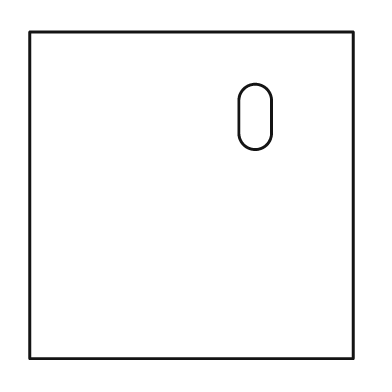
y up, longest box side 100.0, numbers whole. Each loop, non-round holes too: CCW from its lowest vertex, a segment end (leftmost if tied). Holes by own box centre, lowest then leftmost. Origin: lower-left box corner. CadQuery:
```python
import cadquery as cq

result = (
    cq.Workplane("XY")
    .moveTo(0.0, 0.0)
    .lineTo(99.0, 0.0)
    .lineTo(99.0, 100.0)
    .lineTo(0.0, 100.0)
    .close()
    .moveTo(64.0, 69.0)
    .threePointArc((69.0, 64.0), (74.0, 69.0))
    .lineTo(74.0, 79.0)
    .threePointArc((69.0, 84.0), (64.0, 79.0))
    .close()
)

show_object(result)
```